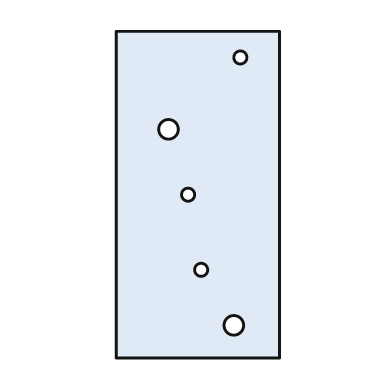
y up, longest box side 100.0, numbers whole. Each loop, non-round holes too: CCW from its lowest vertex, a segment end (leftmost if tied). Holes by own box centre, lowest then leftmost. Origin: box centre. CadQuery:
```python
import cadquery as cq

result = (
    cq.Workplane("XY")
    .moveTo(-25.0, -50.0)
    .lineTo(25.0, -50.0)
    .lineTo(25.0, 50.0)
    .lineTo(-25.0, 50.0)
    .close()
    .moveTo(11.0, -40.0)
    .circle(3.0)
    .moveTo(1.0, -23.0)
    .circle(2.0)
    .moveTo(-3.0, 0.0)
    .circle(2.0)
    .moveTo(-9.0, 20.0)
    .circle(3.0)
    .moveTo(13.0, 42.0)
    .circle(2.0)
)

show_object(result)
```